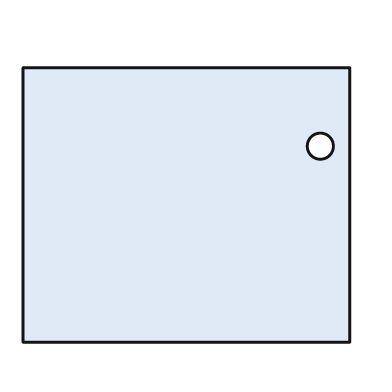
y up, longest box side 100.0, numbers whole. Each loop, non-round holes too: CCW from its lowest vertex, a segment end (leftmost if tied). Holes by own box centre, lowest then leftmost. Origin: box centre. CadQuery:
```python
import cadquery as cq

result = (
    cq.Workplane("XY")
    .moveTo(-50.0, -42.0)
    .lineTo(50.0, -42.0)
    .lineTo(50.0, 42.0)
    .lineTo(-50.0, 42.0)
    .close()
    .moveTo(41.0, 18.0)
    .circle(4.0)
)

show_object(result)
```